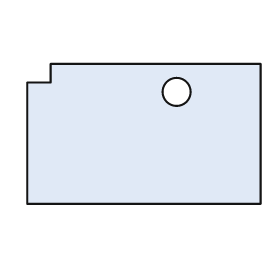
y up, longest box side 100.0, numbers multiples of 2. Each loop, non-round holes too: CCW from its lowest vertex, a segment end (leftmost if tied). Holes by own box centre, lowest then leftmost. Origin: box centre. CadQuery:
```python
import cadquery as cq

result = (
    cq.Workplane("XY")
    .moveTo(-50.0, -30.0)
    .lineTo(50.0, -30.0)
    .lineTo(50.0, 30.0)
    .lineTo(-40.0, 30.0)
    .lineTo(-40.0, 22.0)
    .lineTo(-50.0, 22.0)
    .close()
    .moveTo(14.0, 18.0)
    .circle(6.0)
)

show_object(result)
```